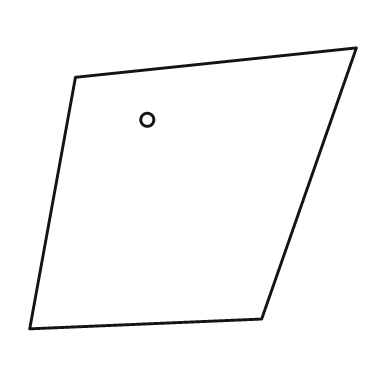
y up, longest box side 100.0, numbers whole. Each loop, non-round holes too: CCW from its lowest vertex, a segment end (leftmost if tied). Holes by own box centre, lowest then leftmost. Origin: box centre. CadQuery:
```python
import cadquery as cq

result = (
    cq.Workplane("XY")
    .moveTo(-50.0, -43.0)
    .lineTo(21.0, -40.0)
    .lineTo(50.0, 43.0)
    .lineTo(-36.0, 34.0)
    .close()
    .moveTo(-14.0, 21.0)
    .circle(2.0)
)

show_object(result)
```